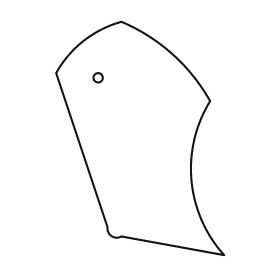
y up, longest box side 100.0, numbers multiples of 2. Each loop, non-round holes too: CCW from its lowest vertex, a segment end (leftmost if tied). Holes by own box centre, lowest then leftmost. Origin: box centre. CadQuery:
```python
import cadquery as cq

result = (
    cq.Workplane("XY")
    .moveTo(36.0, -50.0)
    .threePointArc((22.0, -18.0), (30.0, 16.0))
    .threePointArc((14.0, 36.0), (-8.0, 50.0))
    .threePointArc((-24.0, 42.0), (-36.0, 28.0))
    .lineTo(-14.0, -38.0)
    .threePointArc((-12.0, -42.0), (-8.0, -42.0))
    .close()
    .moveTo(-18.0, 26.0)
    .circle(2.0)
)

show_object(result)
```